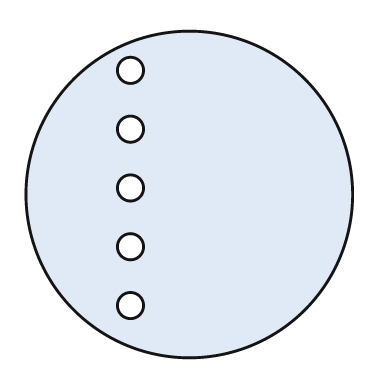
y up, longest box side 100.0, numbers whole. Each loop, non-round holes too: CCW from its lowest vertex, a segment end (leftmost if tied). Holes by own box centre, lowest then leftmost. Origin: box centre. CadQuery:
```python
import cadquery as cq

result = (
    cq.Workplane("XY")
    .moveTo(0.0, 0.0)
    .circle(50.0)
    .moveTo(-18.0, -34.0)
    .circle(4.0)
    .moveTo(-18.0, -16.0)
    .circle(4.0)
    .moveTo(-18.0, 2.0)
    .circle(4.0)
    .moveTo(-18.0, 20.0)
    .circle(4.0)
    .moveTo(-18.0, 38.0)
    .circle(4.0)
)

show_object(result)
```